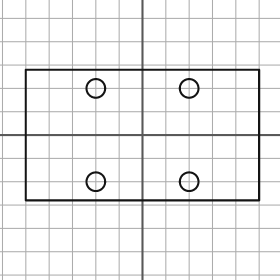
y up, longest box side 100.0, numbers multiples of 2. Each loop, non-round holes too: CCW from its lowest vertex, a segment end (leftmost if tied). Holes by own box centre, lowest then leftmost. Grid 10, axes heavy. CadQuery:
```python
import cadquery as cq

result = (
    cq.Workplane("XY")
    .moveTo(-50.0, -28.0)
    .lineTo(50.0, -28.0)
    .lineTo(50.0, 28.0)
    .lineTo(-50.0, 28.0)
    .close()
    .moveTo(-20.0, -20.0)
    .circle(4.0)
    .moveTo(20.0, -20.0)
    .circle(4.0)
    .moveTo(-20.0, 20.0)
    .circle(4.0)
    .moveTo(20.0, 20.0)
    .circle(4.0)
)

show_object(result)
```